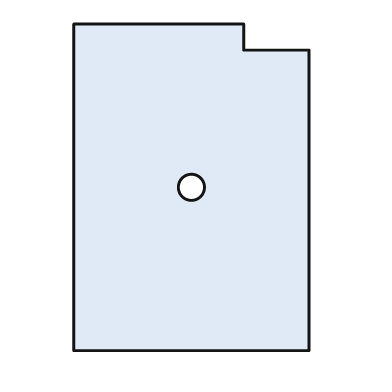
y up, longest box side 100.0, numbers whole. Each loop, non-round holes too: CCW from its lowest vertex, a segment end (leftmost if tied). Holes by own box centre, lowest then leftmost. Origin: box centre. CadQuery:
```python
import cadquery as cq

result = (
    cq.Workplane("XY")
    .moveTo(-36.0, -50.0)
    .lineTo(36.0, -50.0)
    .lineTo(36.0, 42.0)
    .lineTo(16.0, 42.0)
    .lineTo(16.0, 50.0)
    .lineTo(-36.0, 50.0)
    .close()
    .moveTo(0.0, 0.0)
    .circle(4.0)
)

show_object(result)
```